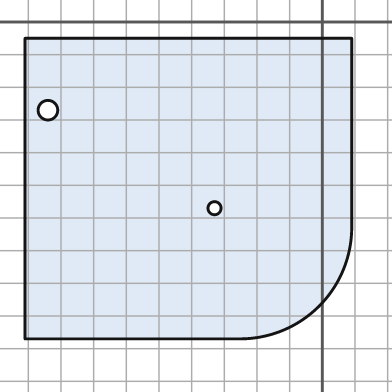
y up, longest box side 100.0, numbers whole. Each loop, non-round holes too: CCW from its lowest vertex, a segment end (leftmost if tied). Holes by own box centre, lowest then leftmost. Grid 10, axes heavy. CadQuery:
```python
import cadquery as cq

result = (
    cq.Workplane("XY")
    .moveTo(-91.0, -97.0)
    .lineTo(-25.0, -97.0)
    .threePointArc((-1.0, -87.0), (9.0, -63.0))
    .lineTo(9.0, -5.0)
    .lineTo(-91.0, -5.0)
    .close()
    .moveTo(-33.0, -57.0)
    .circle(2.0)
    .moveTo(-84.0, -27.0)
    .circle(3.0)
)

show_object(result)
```